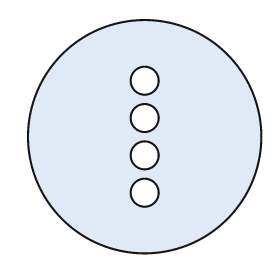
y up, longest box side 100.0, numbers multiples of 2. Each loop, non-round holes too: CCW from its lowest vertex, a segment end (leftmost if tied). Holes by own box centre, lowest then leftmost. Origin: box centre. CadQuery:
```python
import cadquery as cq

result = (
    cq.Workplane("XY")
    .moveTo(0.0, 0.0)
    .circle(50.0)
    .moveTo(0.0, -24.0)
    .circle(6.0)
    .moveTo(0.0, -8.0)
    .circle(6.0)
    .moveTo(0.0, 8.0)
    .circle(6.0)
    .moveTo(0.0, 24.0)
    .circle(6.0)
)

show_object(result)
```